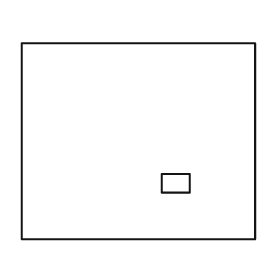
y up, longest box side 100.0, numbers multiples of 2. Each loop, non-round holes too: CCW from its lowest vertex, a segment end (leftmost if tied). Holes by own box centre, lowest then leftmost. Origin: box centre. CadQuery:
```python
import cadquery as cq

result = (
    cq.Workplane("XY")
    .moveTo(-50.0, -42.0)
    .lineTo(50.0, -42.0)
    .lineTo(50.0, 42.0)
    .lineTo(-50.0, 42.0)
    .close()
    .moveTo(10.0, -22.0)
    .lineTo(22.0, -22.0)
    .lineTo(22.0, -14.0)
    .lineTo(10.0, -14.0)
    .close()
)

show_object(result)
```